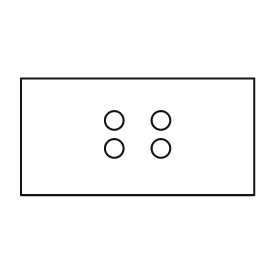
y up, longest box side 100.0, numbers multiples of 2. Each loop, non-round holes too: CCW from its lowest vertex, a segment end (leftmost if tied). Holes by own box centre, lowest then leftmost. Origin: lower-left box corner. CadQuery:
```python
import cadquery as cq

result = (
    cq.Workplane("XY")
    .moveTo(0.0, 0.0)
    .lineTo(100.0, 0.0)
    .lineTo(100.0, 50.0)
    .lineTo(0.0, 50.0)
    .close()
    .moveTo(40.0, 20.0)
    .circle(4.0)
    .moveTo(60.0, 20.0)
    .circle(4.0)
    .moveTo(40.0, 32.0)
    .circle(4.0)
    .moveTo(60.0, 32.0)
    .circle(4.0)
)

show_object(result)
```